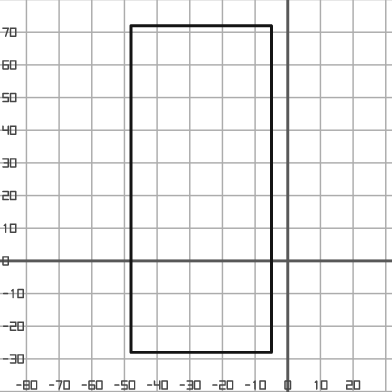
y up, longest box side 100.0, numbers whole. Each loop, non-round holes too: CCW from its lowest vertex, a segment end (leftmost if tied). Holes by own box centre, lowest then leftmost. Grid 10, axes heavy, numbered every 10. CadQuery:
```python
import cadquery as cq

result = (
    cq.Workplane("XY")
    .moveTo(-48.0, -28.0)
    .lineTo(-5.0, -28.0)
    .lineTo(-5.0, 72.0)
    .lineTo(-48.0, 72.0)
    .close()
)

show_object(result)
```